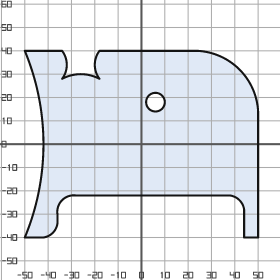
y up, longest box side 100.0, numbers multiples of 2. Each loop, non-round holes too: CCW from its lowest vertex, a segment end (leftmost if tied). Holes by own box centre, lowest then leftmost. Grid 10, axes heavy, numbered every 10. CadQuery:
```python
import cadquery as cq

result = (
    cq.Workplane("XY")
    .moveTo(-50.0, -40.0)
    .lineTo(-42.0, -40.0)
    .threePointArc((-38.0, -38.0), (-36.0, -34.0))
    .lineTo(-36.0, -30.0)
    .threePointArc((-34.0, -24.0), (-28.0, -22.0))
    .lineTo(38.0, -22.0)
    .threePointArc((42.0, -24.0), (44.0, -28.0))
    .lineTo(44.0, -40.0)
    .lineTo(50.0, -40.0)
    .lineTo(50.0, 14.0)
    .threePointArc((42.0, 32.0), (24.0, 40.0))
    .lineTo(-18.0, 40.0)
    .threePointArc((-20.0, 34.0), (-18.0, 28.0))
    .threePointArc((-26.0, 30.0), (-34.0, 28.0))
    .threePointArc((-32.0, 34.0), (-34.0, 40.0))
    .lineTo(-50.0, 40.0)
    .threePointArc((-42.0, 0.0), (-50.0, -40.0))
    .close()
    .moveTo(6.0, 18.0)
    .circle(4.0)
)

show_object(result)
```